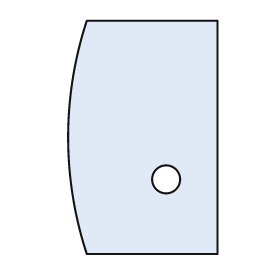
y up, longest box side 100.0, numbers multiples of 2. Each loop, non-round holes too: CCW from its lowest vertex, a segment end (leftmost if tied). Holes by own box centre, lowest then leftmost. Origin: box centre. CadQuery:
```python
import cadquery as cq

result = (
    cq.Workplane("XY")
    .moveTo(-24.0, -50.0)
    .lineTo(32.0, -50.0)
    .lineTo(32.0, 50.0)
    .lineTo(-24.0, 50.0)
    .threePointArc((-32.0, 0.0), (-24.0, -50.0))
    .close()
    .moveTo(10.0, -18.0)
    .circle(6.0)
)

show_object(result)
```